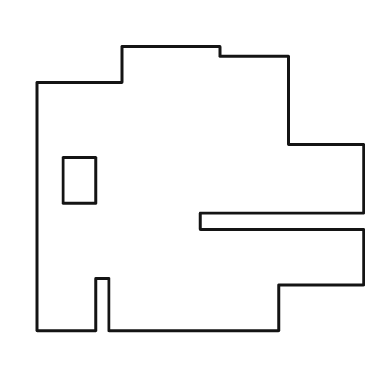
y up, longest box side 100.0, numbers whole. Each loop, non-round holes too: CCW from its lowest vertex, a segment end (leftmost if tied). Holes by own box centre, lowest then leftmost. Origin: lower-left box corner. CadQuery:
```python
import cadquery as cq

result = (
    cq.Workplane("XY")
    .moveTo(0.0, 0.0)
    .lineTo(18.0, 0.0)
    .lineTo(18.0, 16.0)
    .lineTo(22.0, 16.0)
    .lineTo(22.0, 0.0)
    .lineTo(74.0, 0.0)
    .lineTo(74.0, 14.0)
    .lineTo(100.0, 14.0)
    .lineTo(100.0, 31.0)
    .lineTo(50.0, 31.0)
    .lineTo(50.0, 36.0)
    .lineTo(100.0, 36.0)
    .lineTo(100.0, 57.0)
    .lineTo(77.0, 57.0)
    .lineTo(77.0, 84.0)
    .lineTo(56.0, 84.0)
    .lineTo(56.0, 87.0)
    .lineTo(26.0, 87.0)
    .lineTo(26.0, 76.0)
    .lineTo(0.0, 76.0)
    .close()
    .moveTo(8.0, 39.0)
    .lineTo(18.0, 39.0)
    .lineTo(18.0, 53.0)
    .lineTo(8.0, 53.0)
    .close()
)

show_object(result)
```